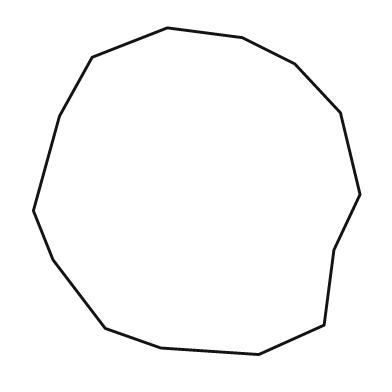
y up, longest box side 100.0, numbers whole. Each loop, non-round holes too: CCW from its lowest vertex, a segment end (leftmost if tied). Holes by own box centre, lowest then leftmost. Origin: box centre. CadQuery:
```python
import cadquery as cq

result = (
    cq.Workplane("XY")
    .moveTo(19.0, -50.0)
    .lineTo(39.0, -41.0)
    .lineTo(42.0, -18.0)
    .lineTo(50.0, -1.0)
    .lineTo(44.0, 24.0)
    .lineTo(30.0, 39.0)
    .lineTo(14.0, 47.0)
    .lineTo(-9.0, 50.0)
    .lineTo(-32.0, 41.0)
    .lineTo(-42.0, 23.0)
    .lineTo(-50.0, -6.0)
    .lineTo(-44.0, -21.0)
    .lineTo(-28.0, -42.0)
    .lineTo(-11.0, -48.0)
    .close()
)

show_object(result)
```